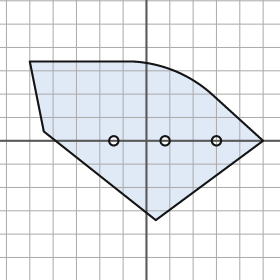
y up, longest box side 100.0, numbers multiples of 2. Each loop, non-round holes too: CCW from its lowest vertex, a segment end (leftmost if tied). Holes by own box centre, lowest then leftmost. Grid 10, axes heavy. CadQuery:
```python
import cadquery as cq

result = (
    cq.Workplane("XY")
    .moveTo(4.0, -34.0)
    .lineTo(50.0, 0.0)
    .lineTo(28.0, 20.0)
    .threePointArc((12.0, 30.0), (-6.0, 34.0))
    .lineTo(-50.0, 34.0)
    .lineTo(-44.0, 4.0)
    .close()
    .moveTo(-14.0, 0.0)
    .circle(2.0)
    .moveTo(8.0, 0.0)
    .circle(2.0)
    .moveTo(30.0, 0.0)
    .circle(2.0)
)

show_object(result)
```